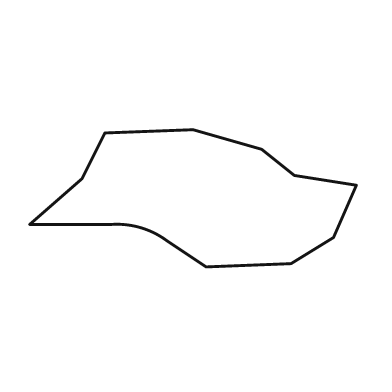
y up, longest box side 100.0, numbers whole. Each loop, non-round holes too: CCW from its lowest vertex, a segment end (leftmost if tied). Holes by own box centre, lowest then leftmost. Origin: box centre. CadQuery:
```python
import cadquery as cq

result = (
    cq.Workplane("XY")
    .moveTo(4.0, -21.0)
    .lineTo(30.0, -20.0)
    .lineTo(43.0, -12.0)
    .lineTo(50.0, 4.0)
    .lineTo(31.0, 7.0)
    .lineTo(21.0, 15.0)
    .lineTo(0.0, 21.0)
    .lineTo(-27.0, 20.0)
    .lineTo(-34.0, 6.0)
    .lineTo(-50.0, -8.0)
    .lineTo(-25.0, -8.0)
    .threePointArc((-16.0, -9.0), (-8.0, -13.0))
    .close()
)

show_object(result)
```